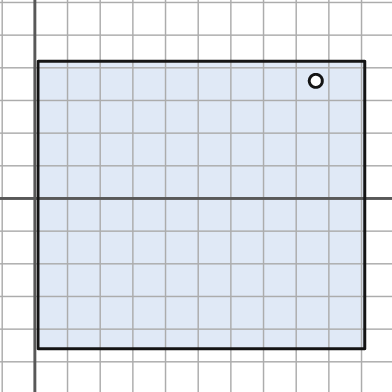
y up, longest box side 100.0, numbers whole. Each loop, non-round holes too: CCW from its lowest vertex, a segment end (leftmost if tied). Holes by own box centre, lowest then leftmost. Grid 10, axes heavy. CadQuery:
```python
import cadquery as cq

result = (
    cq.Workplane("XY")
    .moveTo(1.0, -46.0)
    .lineTo(101.0, -46.0)
    .lineTo(101.0, 42.0)
    .lineTo(1.0, 42.0)
    .close()
    .moveTo(86.0, 36.0)
    .circle(2.0)
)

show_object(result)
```